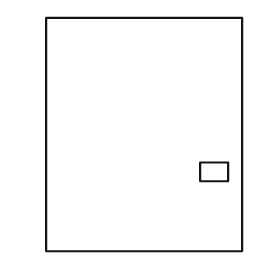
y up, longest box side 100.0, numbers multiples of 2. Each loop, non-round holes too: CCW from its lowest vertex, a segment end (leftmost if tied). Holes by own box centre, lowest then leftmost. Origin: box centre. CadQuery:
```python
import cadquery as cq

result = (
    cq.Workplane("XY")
    .moveTo(-42.0, -50.0)
    .lineTo(42.0, -50.0)
    .lineTo(42.0, 50.0)
    .lineTo(-42.0, 50.0)
    .close()
    .moveTo(24.0, -20.0)
    .lineTo(36.0, -20.0)
    .lineTo(36.0, -12.0)
    .lineTo(24.0, -12.0)
    .close()
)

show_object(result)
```